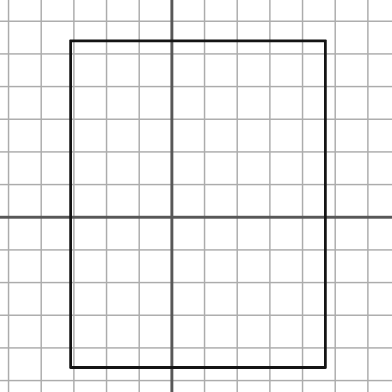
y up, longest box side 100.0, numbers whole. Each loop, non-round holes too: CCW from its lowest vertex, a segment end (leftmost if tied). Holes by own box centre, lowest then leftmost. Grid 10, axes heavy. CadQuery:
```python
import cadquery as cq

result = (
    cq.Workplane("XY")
    .moveTo(-31.0, -46.0)
    .lineTo(47.0, -46.0)
    .lineTo(47.0, 54.0)
    .lineTo(-31.0, 54.0)
    .close()
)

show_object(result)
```